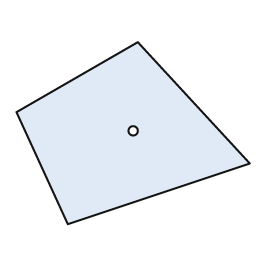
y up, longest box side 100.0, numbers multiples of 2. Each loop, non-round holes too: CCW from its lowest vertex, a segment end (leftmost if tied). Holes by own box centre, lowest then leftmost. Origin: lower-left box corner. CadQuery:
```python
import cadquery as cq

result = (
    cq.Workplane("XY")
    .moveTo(22.0, 0.0)
    .lineTo(100.0, 26.0)
    .lineTo(52.0, 78.0)
    .lineTo(0.0, 48.0)
    .close()
    .moveTo(50.0, 40.0)
    .circle(2.0)
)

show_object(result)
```